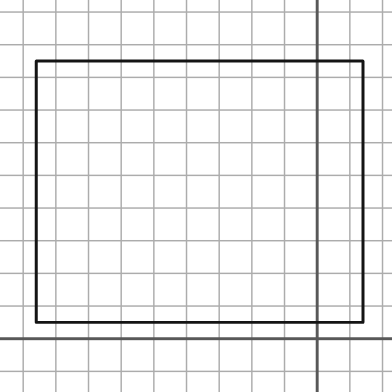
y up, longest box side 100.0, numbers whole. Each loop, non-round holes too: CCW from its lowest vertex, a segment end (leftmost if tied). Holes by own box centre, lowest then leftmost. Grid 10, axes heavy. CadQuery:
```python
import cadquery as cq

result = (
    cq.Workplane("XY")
    .moveTo(-86.0, 5.0)
    .lineTo(14.0, 5.0)
    .lineTo(14.0, 85.0)
    .lineTo(-86.0, 85.0)
    .close()
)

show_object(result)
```